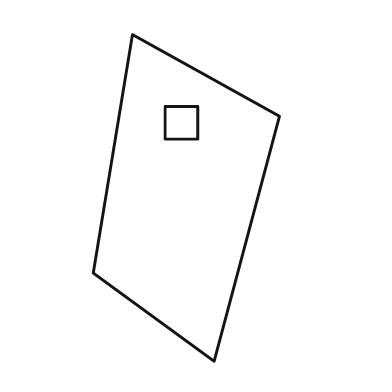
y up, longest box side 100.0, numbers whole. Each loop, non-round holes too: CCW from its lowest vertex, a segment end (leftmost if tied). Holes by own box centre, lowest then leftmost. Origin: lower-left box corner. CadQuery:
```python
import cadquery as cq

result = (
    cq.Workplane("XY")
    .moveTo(37.0, 0.0)
    .lineTo(57.0, 75.0)
    .lineTo(12.0, 100.0)
    .lineTo(0.0, 27.0)
    .close()
    .moveTo(22.0, 68.0)
    .lineTo(32.0, 68.0)
    .lineTo(32.0, 78.0)
    .lineTo(22.0, 78.0)
    .close()
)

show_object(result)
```